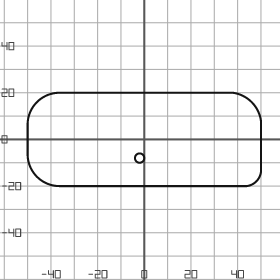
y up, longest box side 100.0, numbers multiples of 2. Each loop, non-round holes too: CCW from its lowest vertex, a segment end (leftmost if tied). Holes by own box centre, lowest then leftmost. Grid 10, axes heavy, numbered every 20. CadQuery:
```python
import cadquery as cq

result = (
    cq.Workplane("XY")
    .moveTo(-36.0, -20.0)
    .lineTo(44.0, -20.0)
    .threePointArc((48.0, -18.0), (50.0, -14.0))
    .lineTo(50.0, 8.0)
    .threePointArc((46.0, 16.0), (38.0, 20.0))
    .lineTo(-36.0, 20.0)
    .threePointArc((-46.0, 16.0), (-50.0, 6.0))
    .lineTo(-50.0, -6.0)
    .threePointArc((-46.0, -16.0), (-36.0, -20.0))
    .close()
    .moveTo(-2.0, -8.0)
    .circle(2.0)
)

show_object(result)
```